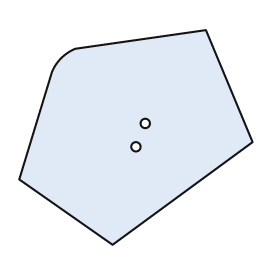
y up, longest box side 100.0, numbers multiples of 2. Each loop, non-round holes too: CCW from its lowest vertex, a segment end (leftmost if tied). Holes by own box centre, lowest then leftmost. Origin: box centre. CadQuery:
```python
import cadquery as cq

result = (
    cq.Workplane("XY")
    .moveTo(-10.0, -46.0)
    .lineTo(50.0, -2.0)
    .lineTo(30.0, 46.0)
    .lineTo(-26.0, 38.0)
    .threePointArc((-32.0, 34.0), (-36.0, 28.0))
    .lineTo(-50.0, -18.0)
    .close()
    .moveTo(0.0, -4.0)
    .circle(2.0)
    .moveTo(4.0, 6.0)
    .circle(2.0)
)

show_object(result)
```